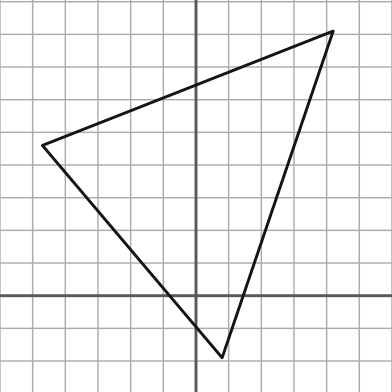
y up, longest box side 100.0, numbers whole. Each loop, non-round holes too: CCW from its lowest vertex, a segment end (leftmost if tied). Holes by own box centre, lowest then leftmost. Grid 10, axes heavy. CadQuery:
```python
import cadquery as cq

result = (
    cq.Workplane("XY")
    .moveTo(8.0, -19.0)
    .lineTo(42.0, 81.0)
    .lineTo(-47.0, 46.0)
    .close()
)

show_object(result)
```